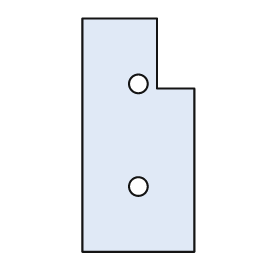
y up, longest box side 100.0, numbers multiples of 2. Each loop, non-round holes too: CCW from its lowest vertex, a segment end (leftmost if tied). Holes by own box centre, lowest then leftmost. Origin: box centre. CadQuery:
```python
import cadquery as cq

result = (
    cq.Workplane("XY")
    .moveTo(-24.0, -50.0)
    .lineTo(24.0, -50.0)
    .lineTo(24.0, 20.0)
    .lineTo(8.0, 20.0)
    .lineTo(8.0, 50.0)
    .lineTo(-24.0, 50.0)
    .close()
    .moveTo(0.0, -22.0)
    .circle(4.0)
    .moveTo(0.0, 22.0)
    .circle(4.0)
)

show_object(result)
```